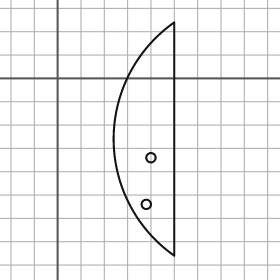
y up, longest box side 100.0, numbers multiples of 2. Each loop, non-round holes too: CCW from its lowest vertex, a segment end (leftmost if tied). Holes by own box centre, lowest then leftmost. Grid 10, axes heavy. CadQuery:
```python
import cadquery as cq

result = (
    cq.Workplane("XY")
    .moveTo(50.0, -76.0)
    .lineTo(50.0, 24.0)
    .threePointArc((24.0, -26.0), (50.0, -76.0))
    .close()
    .moveTo(38.0, -54.0)
    .circle(2.0)
    .moveTo(40.0, -34.0)
    .circle(2.0)
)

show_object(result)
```